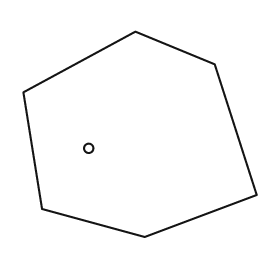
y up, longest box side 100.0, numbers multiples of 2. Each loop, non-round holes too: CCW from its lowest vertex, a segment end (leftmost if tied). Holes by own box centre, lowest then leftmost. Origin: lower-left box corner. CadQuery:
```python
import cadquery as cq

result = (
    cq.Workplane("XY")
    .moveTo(52.0, 0.0)
    .lineTo(100.0, 18.0)
    .lineTo(82.0, 74.0)
    .lineTo(48.0, 88.0)
    .lineTo(0.0, 62.0)
    .lineTo(8.0, 12.0)
    .close()
    .moveTo(28.0, 38.0)
    .circle(2.0)
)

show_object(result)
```